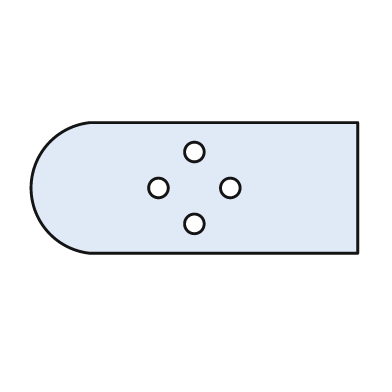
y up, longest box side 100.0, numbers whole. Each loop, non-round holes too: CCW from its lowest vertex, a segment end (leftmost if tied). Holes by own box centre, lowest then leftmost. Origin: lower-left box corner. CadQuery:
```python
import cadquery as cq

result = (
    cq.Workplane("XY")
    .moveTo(18.0, 0.0)
    .lineTo(100.0, 0.0)
    .lineTo(100.0, 40.0)
    .lineTo(18.0, 40.0)
    .threePointArc((0.0, 20.0), (18.0, 0.0))
    .close()
    .moveTo(50.0, 9.0)
    .circle(3.0)
    .moveTo(39.0, 20.0)
    .circle(3.0)
    .moveTo(61.0, 20.0)
    .circle(3.0)
    .moveTo(50.0, 31.0)
    .circle(3.0)
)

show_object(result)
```